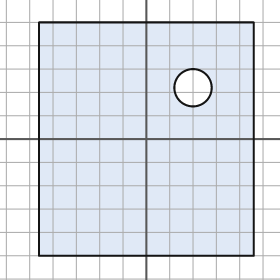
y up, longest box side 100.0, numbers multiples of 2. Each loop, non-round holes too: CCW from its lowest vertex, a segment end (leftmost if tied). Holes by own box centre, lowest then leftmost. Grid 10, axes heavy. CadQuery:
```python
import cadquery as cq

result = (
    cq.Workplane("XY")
    .moveTo(-46.0, -50.0)
    .lineTo(46.0, -50.0)
    .lineTo(46.0, 50.0)
    .lineTo(-46.0, 50.0)
    .close()
    .moveTo(20.0, 22.0)
    .circle(8.0)
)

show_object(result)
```